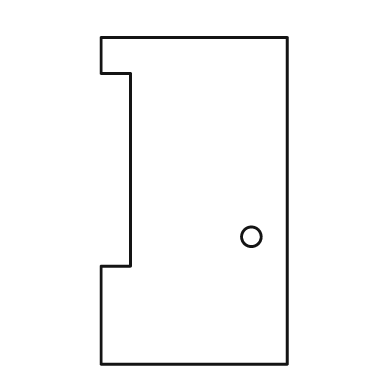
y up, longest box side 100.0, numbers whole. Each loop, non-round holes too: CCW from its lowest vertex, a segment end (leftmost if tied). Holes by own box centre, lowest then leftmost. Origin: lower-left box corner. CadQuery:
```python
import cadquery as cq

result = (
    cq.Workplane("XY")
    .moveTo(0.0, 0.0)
    .lineTo(57.0, 0.0)
    .lineTo(57.0, 100.0)
    .lineTo(0.0, 100.0)
    .lineTo(0.0, 89.0)
    .lineTo(9.0, 89.0)
    .lineTo(9.0, 30.0)
    .lineTo(0.0, 30.0)
    .close()
    .moveTo(46.0, 39.0)
    .circle(3.0)
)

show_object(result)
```